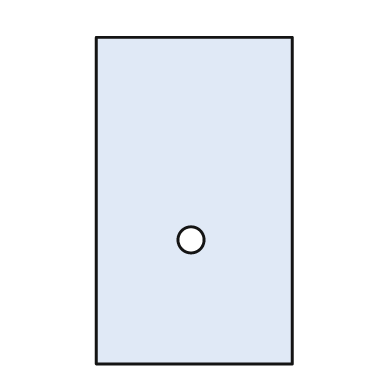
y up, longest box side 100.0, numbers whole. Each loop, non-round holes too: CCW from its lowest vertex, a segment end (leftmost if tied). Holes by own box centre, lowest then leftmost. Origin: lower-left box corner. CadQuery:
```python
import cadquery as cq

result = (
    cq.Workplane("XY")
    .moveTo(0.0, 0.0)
    .lineTo(60.0, 0.0)
    .lineTo(60.0, 100.0)
    .lineTo(0.0, 100.0)
    .close()
    .moveTo(29.0, 38.0)
    .circle(4.0)
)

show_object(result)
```